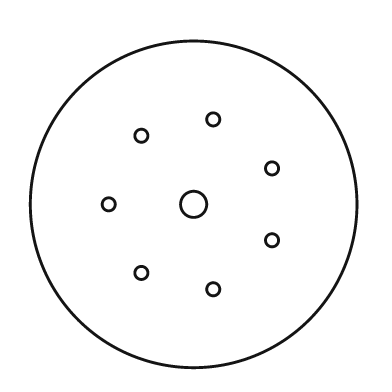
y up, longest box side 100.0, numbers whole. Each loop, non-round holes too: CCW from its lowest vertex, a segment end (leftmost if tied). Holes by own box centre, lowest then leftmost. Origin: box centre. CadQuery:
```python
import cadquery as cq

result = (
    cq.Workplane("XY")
    .moveTo(0.0, 0.0)
    .circle(50.0)
    .moveTo(6.0, -26.0)
    .circle(2.0)
    .moveTo(-16.0, -21.0)
    .circle(2.0)
    .moveTo(24.0, -11.0)
    .circle(2.0)
    .moveTo(-26.0, 0.0)
    .circle(2.0)
    .moveTo(0.0, 0.0)
    .circle(4.0)
    .moveTo(24.0, 11.0)
    .circle(2.0)
    .moveTo(-16.0, 21.0)
    .circle(2.0)
    .moveTo(6.0, 26.0)
    .circle(2.0)
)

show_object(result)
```